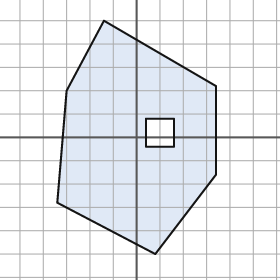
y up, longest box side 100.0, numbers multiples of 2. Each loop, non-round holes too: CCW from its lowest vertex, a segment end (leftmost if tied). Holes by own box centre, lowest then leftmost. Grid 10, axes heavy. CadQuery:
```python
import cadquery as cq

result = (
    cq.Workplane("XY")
    .moveTo(8.0, -50.0)
    .lineTo(34.0, -16.0)
    .lineTo(34.0, 22.0)
    .lineTo(-14.0, 50.0)
    .lineTo(-30.0, 20.0)
    .lineTo(-34.0, -28.0)
    .close()
    .moveTo(4.0, -4.0)
    .lineTo(16.0, -4.0)
    .lineTo(16.0, 8.0)
    .lineTo(4.0, 8.0)
    .close()
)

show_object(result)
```